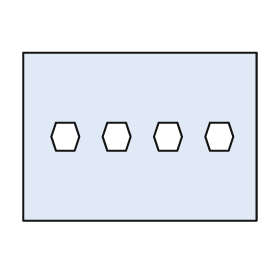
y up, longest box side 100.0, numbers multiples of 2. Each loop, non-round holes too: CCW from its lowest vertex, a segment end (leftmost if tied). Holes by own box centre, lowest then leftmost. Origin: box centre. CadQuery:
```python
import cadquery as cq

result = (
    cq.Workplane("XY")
    .moveTo(-50.0, -36.0)
    .lineTo(50.0, -36.0)
    .lineTo(50.0, 36.0)
    .lineTo(-50.0, 36.0)
    .close()
    .moveTo(-36.0, -6.0)
    .lineTo(-28.0, -6.0)
    .lineTo(-26.0, 0.0)
    .lineTo(-28.0, 6.0)
    .lineTo(-36.0, 6.0)
    .lineTo(-38.0, 0.0)
    .close()
    .moveTo(-14.0, -6.0)
    .lineTo(-6.0, -6.0)
    .lineTo(-4.0, 0.0)
    .lineTo(-6.0, 6.0)
    .lineTo(-14.0, 6.0)
    .lineTo(-16.0, 0.0)
    .close()
    .moveTo(8.0, -6.0)
    .lineTo(16.0, -6.0)
    .lineTo(18.0, 0.0)
    .lineTo(16.0, 6.0)
    .lineTo(8.0, 6.0)
    .lineTo(6.0, 0.0)
    .close()
    .moveTo(30.0, -6.0)
    .lineTo(38.0, -6.0)
    .lineTo(40.0, 0.0)
    .lineTo(38.0, 6.0)
    .lineTo(30.0, 6.0)
    .lineTo(28.0, 0.0)
    .close()
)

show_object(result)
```